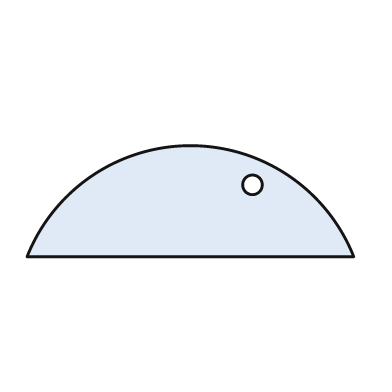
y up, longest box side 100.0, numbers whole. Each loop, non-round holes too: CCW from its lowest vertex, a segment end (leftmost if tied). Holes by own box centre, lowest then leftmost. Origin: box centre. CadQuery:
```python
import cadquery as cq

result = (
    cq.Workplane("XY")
    .moveTo(-50.0, -17.0)
    .lineTo(50.0, -17.0)
    .threePointArc((0.0, 17.0), (-50.0, -17.0))
    .close()
    .moveTo(19.0, 5.0)
    .circle(3.0)
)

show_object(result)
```